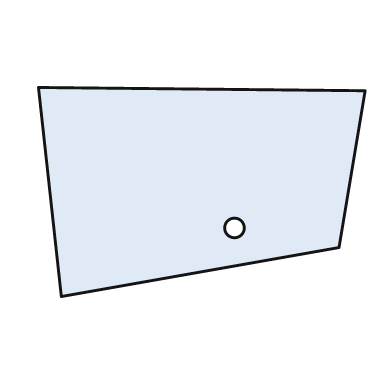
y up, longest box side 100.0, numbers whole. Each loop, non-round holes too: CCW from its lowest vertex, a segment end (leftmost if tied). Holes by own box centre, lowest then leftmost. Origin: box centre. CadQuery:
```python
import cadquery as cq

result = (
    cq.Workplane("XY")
    .moveTo(-43.0, -32.0)
    .lineTo(42.0, -17.0)
    .lineTo(50.0, 31.0)
    .lineTo(-50.0, 32.0)
    .close()
    .moveTo(10.0, -11.0)
    .circle(3.0)
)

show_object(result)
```